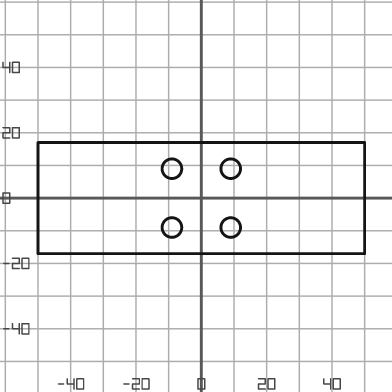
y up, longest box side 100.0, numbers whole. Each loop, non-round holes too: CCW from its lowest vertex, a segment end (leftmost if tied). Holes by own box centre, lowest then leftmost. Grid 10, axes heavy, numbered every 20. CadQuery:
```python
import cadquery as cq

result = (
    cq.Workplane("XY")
    .moveTo(-50.0, -17.0)
    .lineTo(50.0, -17.0)
    .lineTo(50.0, 17.0)
    .lineTo(-50.0, 17.0)
    .close()
    .moveTo(-9.0, -9.0)
    .circle(3.0)
    .moveTo(9.0, -9.0)
    .circle(3.0)
    .moveTo(-9.0, 9.0)
    .circle(3.0)
    .moveTo(9.0, 9.0)
    .circle(3.0)
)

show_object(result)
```